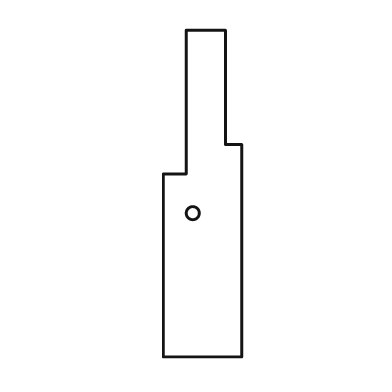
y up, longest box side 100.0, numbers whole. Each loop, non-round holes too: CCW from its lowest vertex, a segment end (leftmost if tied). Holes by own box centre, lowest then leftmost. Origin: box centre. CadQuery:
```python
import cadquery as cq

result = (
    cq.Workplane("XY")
    .moveTo(-12.0, -50.0)
    .lineTo(12.0, -50.0)
    .lineTo(12.0, 15.0)
    .lineTo(7.0, 15.0)
    .lineTo(7.0, 50.0)
    .lineTo(-5.0, 50.0)
    .lineTo(-5.0, 6.0)
    .lineTo(-12.0, 6.0)
    .close()
    .moveTo(-3.0, -6.0)
    .circle(2.0)
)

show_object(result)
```